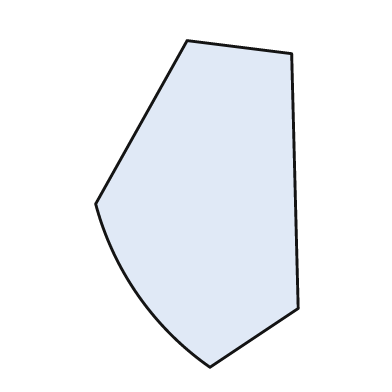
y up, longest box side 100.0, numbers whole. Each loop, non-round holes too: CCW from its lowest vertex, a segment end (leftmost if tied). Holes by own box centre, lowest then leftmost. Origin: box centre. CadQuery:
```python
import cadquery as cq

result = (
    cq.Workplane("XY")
    .moveTo(4.0, -50.0)
    .lineTo(31.0, -32.0)
    .lineTo(29.0, 46.0)
    .lineTo(-3.0, 50.0)
    .lineTo(-31.0, 0.0)
    .threePointArc((-18.0, -28.0), (4.0, -50.0))
    .close()
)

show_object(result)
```